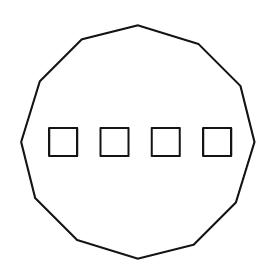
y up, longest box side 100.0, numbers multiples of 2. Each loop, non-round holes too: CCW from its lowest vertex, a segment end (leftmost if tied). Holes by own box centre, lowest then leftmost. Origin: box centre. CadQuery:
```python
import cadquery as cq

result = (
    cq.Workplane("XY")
    .moveTo(0.0, -50.0)
    .lineTo(24.0, -44.0)
    .lineTo(42.0, -26.0)
    .lineTo(50.0, 0.0)
    .lineTo(44.0, 24.0)
    .lineTo(26.0, 42.0)
    .lineTo(0.0, 50.0)
    .lineTo(-24.0, 44.0)
    .lineTo(-42.0, 26.0)
    .lineTo(-50.0, 0.0)
    .lineTo(-44.0, -24.0)
    .lineTo(-26.0, -42.0)
    .close()
    .moveTo(-38.0, -6.0)
    .lineTo(-26.0, -6.0)
    .lineTo(-26.0, 6.0)
    .lineTo(-38.0, 6.0)
    .close()
    .moveTo(-16.0, -6.0)
    .lineTo(-4.0, -6.0)
    .lineTo(-4.0, 6.0)
    .lineTo(-16.0, 6.0)
    .close()
    .moveTo(6.0, -6.0)
    .lineTo(18.0, -6.0)
    .lineTo(18.0, 6.0)
    .lineTo(6.0, 6.0)
    .close()
    .moveTo(28.0, -6.0)
    .lineTo(40.0, -6.0)
    .lineTo(40.0, 6.0)
    .lineTo(28.0, 6.0)
    .close()
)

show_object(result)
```